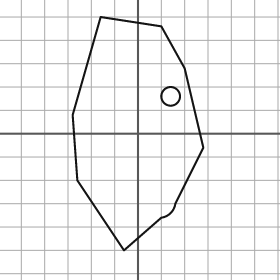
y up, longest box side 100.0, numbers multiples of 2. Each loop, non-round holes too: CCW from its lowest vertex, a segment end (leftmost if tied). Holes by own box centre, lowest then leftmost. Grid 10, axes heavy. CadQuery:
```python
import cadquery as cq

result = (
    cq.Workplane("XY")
    .moveTo(-6.0, -50.0)
    .lineTo(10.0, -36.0)
    .threePointArc((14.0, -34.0), (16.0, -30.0))
    .lineTo(28.0, -6.0)
    .lineTo(20.0, 28.0)
    .lineTo(10.0, 46.0)
    .lineTo(-16.0, 50.0)
    .lineTo(-28.0, 8.0)
    .lineTo(-26.0, -20.0)
    .close()
    .moveTo(14.0, 16.0)
    .circle(4.0)
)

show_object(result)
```